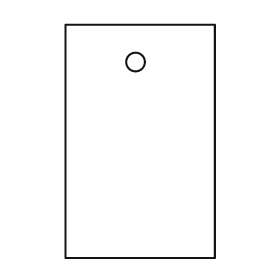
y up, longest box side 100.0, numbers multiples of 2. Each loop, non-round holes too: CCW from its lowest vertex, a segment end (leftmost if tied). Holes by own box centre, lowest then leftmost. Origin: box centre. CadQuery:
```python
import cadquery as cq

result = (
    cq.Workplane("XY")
    .moveTo(-32.0, -50.0)
    .lineTo(32.0, -50.0)
    .lineTo(32.0, 50.0)
    .lineTo(-32.0, 50.0)
    .close()
    .moveTo(-2.0, 34.0)
    .circle(4.0)
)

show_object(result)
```